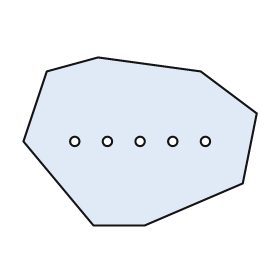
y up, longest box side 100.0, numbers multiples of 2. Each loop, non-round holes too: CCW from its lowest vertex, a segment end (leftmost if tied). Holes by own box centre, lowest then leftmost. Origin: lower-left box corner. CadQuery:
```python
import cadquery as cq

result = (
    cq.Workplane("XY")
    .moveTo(30.0, 0.0)
    .lineTo(52.0, 0.0)
    .lineTo(94.0, 18.0)
    .lineTo(100.0, 48.0)
    .lineTo(76.0, 66.0)
    .lineTo(32.0, 72.0)
    .lineTo(10.0, 66.0)
    .lineTo(0.0, 36.0)
    .close()
    .moveTo(22.0, 36.0)
    .circle(2.0)
    .moveTo(36.0, 36.0)
    .circle(2.0)
    .moveTo(50.0, 36.0)
    .circle(2.0)
    .moveTo(64.0, 36.0)
    .circle(2.0)
    .moveTo(78.0, 36.0)
    .circle(2.0)
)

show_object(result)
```